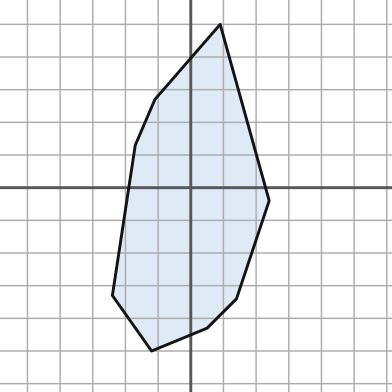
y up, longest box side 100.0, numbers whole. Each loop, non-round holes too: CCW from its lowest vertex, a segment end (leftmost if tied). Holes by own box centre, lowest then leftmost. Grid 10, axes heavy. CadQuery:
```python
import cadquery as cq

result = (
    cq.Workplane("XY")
    .moveTo(-12.0, -50.0)
    .lineTo(5.0, -43.0)
    .lineTo(14.0, -34.0)
    .lineTo(24.0, -4.0)
    .lineTo(9.0, 50.0)
    .lineTo(-11.0, 27.0)
    .lineTo(-17.0, 13.0)
    .lineTo(-24.0, -33.0)
    .close()
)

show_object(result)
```